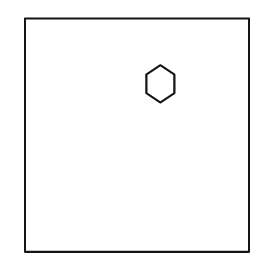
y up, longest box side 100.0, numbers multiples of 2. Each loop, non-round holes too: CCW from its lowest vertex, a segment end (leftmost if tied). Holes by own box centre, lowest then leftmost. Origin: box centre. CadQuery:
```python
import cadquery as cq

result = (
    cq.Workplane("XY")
    .moveTo(-48.0, -50.0)
    .lineTo(48.0, -50.0)
    .lineTo(48.0, 50.0)
    .lineTo(-48.0, 50.0)
    .close()
    .moveTo(10.0, 14.0)
    .lineTo(16.0, 18.0)
    .lineTo(16.0, 26.0)
    .lineTo(10.0, 30.0)
    .lineTo(4.0, 26.0)
    .lineTo(4.0, 18.0)
    .close()
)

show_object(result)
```